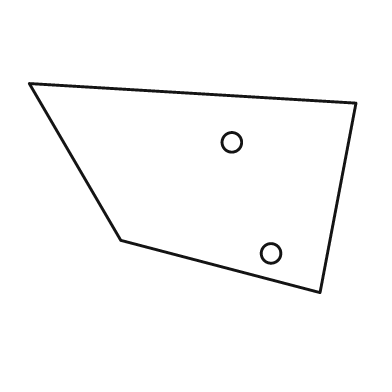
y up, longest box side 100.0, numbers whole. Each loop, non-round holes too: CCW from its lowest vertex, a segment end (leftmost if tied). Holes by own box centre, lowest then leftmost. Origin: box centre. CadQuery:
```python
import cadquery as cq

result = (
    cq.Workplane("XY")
    .moveTo(39.0, -32.0)
    .lineTo(50.0, 26.0)
    .lineTo(-50.0, 32.0)
    .lineTo(-22.0, -16.0)
    .close()
    .moveTo(24.0, -20.0)
    .circle(3.0)
    .moveTo(12.0, 14.0)
    .circle(3.0)
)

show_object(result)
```